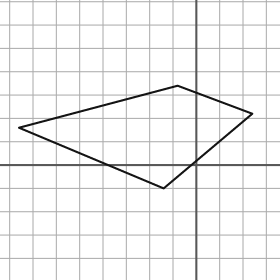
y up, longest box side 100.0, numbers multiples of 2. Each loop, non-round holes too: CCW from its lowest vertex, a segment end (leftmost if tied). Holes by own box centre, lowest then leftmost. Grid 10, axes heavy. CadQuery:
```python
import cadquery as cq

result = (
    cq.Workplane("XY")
    .moveTo(-14.0, -10.0)
    .lineTo(24.0, 22.0)
    .lineTo(-8.0, 34.0)
    .lineTo(-76.0, 16.0)
    .close()
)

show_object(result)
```